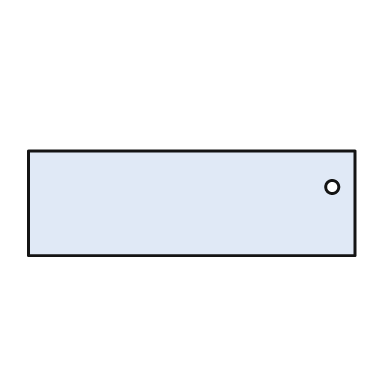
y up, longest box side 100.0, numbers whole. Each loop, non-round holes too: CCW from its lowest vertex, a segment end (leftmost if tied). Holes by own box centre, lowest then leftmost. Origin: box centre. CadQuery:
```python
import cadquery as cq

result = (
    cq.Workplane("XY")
    .moveTo(-50.0, -16.0)
    .lineTo(50.0, -16.0)
    .lineTo(50.0, 16.0)
    .lineTo(-50.0, 16.0)
    .close()
    .moveTo(43.0, 5.0)
    .circle(2.0)
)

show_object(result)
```